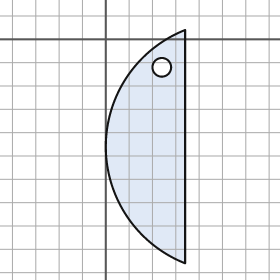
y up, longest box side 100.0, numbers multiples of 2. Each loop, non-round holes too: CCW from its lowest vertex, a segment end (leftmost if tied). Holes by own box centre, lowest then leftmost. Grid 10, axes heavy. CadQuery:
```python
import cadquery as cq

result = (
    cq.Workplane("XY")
    .moveTo(34.0, -96.0)
    .lineTo(34.0, 4.0)
    .threePointArc((0.0, -46.0), (34.0, -96.0))
    .close()
    .moveTo(24.0, -12.0)
    .circle(4.0)
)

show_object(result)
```